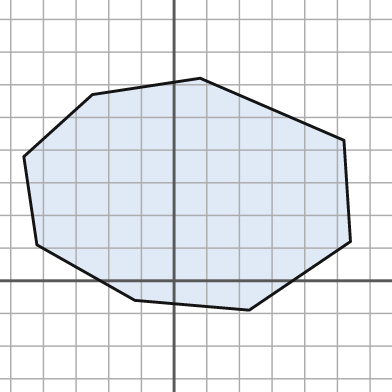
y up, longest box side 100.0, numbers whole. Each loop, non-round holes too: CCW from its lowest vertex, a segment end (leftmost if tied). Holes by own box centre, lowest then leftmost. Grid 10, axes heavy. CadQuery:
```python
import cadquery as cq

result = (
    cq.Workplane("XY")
    .moveTo(23.0, -9.0)
    .lineTo(54.0, 12.0)
    .lineTo(52.0, 43.0)
    .lineTo(8.0, 62.0)
    .lineTo(-25.0, 57.0)
    .lineTo(-46.0, 38.0)
    .lineTo(-42.0, 11.0)
    .lineTo(-12.0, -6.0)
    .close()
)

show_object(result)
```